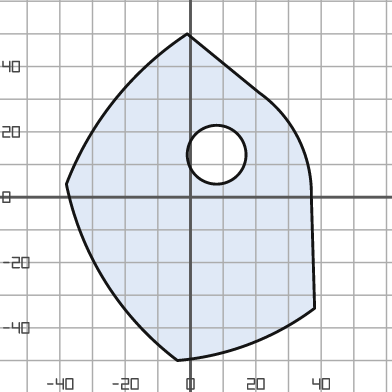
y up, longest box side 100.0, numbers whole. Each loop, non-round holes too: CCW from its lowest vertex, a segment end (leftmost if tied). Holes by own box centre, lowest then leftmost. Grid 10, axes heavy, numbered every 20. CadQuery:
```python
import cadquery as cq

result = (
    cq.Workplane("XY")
    .moveTo(-4.0, -50.0)
    .threePointArc((18.0, -45.0), (38.0, -34.0))
    .lineTo(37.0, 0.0)
    .threePointArc((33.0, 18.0), (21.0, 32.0))
    .lineTo(-1.0, 50.0)
    .threePointArc((-23.0, 30.0), (-38.0, 4.0))
    .threePointArc((-26.0, -26.0), (-4.0, -50.0))
    .close()
    .moveTo(8.0, 13.0)
    .circle(9.0)
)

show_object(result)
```